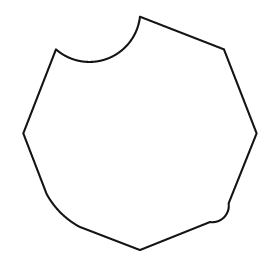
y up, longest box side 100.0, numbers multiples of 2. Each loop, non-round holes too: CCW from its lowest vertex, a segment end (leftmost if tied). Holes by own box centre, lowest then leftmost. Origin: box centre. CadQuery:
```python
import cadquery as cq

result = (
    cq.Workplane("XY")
    .moveTo(0.0, -50.0)
    .lineTo(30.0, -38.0)
    .threePointArc((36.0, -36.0), (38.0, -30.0))
    .lineTo(50.0, 0.0)
    .lineTo(36.0, 36.0)
    .lineTo(0.0, 50.0)
    .threePointArc((-14.0, 32.0), (-36.0, 36.0))
    .lineTo(-50.0, 0.0)
    .lineTo(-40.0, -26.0)
    .threePointArc((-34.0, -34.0), (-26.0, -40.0))
    .close()
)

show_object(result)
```